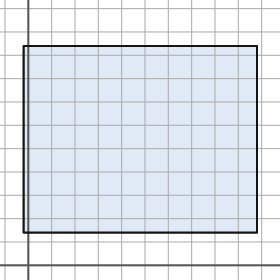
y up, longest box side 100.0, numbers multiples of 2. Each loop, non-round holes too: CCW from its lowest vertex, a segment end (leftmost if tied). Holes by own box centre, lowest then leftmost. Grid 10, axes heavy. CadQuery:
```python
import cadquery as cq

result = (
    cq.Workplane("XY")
    .moveTo(-2.0, 14.0)
    .lineTo(98.0, 14.0)
    .lineTo(98.0, 94.0)
    .lineTo(-2.0, 94.0)
    .close()
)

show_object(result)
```